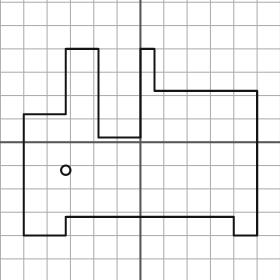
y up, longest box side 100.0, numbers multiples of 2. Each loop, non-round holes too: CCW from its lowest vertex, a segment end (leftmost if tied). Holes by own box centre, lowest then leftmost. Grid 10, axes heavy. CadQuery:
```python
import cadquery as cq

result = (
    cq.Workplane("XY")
    .moveTo(-50.0, -40.0)
    .lineTo(-32.0, -40.0)
    .lineTo(-32.0, -32.0)
    .lineTo(40.0, -32.0)
    .lineTo(40.0, -40.0)
    .lineTo(50.0, -40.0)
    .lineTo(50.0, 22.0)
    .lineTo(6.0, 22.0)
    .lineTo(6.0, 40.0)
    .lineTo(0.0, 40.0)
    .lineTo(0.0, 2.0)
    .lineTo(-18.0, 2.0)
    .lineTo(-18.0, 40.0)
    .lineTo(-32.0, 40.0)
    .lineTo(-32.0, 12.0)
    .lineTo(-50.0, 12.0)
    .close()
    .moveTo(-32.0, -12.0)
    .circle(2.0)
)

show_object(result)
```